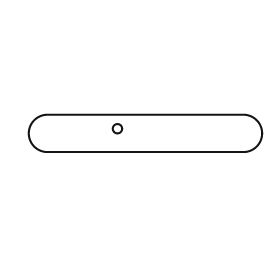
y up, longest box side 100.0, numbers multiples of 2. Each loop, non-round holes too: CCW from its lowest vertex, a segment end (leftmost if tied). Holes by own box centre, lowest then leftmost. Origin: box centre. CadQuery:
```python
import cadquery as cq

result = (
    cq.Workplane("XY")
    .moveTo(-42.0, -8.0)
    .lineTo(42.0, -8.0)
    .threePointArc((50.0, 0.0), (42.0, 8.0))
    .lineTo(-42.0, 8.0)
    .threePointArc((-50.0, 0.0), (-42.0, -8.0))
    .close()
    .moveTo(-12.0, 2.0)
    .circle(2.0)
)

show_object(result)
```